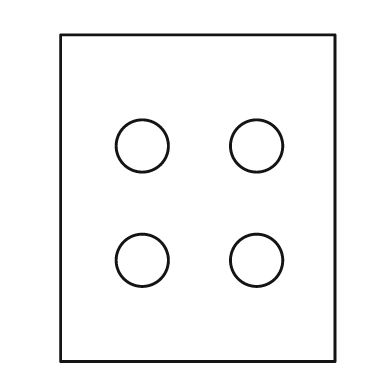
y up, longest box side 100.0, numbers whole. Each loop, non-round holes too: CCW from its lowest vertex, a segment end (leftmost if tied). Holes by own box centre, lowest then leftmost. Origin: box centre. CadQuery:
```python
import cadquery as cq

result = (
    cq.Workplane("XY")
    .moveTo(-42.0, -50.0)
    .lineTo(42.0, -50.0)
    .lineTo(42.0, 50.0)
    .lineTo(-42.0, 50.0)
    .close()
    .moveTo(-17.0, -19.0)
    .circle(8.0)
    .moveTo(18.0, -19.0)
    .circle(8.0)
    .moveTo(-17.0, 16.0)
    .circle(8.0)
    .moveTo(18.0, 16.0)
    .circle(8.0)
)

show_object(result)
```